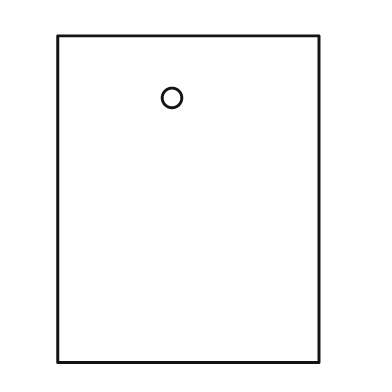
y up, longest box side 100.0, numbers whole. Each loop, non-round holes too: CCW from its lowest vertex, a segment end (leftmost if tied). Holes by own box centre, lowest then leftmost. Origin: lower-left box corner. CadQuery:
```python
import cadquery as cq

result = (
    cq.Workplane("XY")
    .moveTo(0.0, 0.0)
    .lineTo(80.0, 0.0)
    .lineTo(80.0, 100.0)
    .lineTo(0.0, 100.0)
    .close()
    .moveTo(35.0, 81.0)
    .circle(3.0)
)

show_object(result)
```